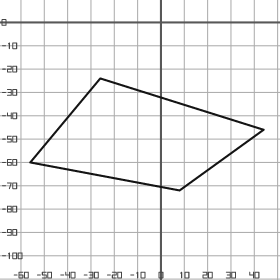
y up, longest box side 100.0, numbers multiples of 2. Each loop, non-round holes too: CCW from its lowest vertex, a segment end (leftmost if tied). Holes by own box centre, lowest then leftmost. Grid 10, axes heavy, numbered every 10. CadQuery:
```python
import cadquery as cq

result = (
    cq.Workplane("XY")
    .moveTo(8.0, -72.0)
    .lineTo(44.0, -46.0)
    .lineTo(-26.0, -24.0)
    .lineTo(-56.0, -60.0)
    .close()
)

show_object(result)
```